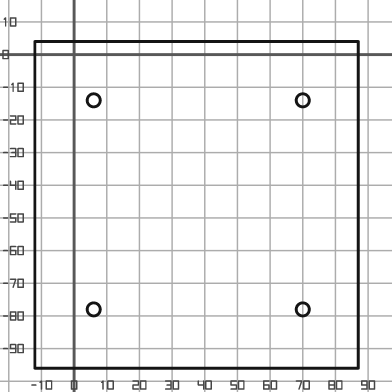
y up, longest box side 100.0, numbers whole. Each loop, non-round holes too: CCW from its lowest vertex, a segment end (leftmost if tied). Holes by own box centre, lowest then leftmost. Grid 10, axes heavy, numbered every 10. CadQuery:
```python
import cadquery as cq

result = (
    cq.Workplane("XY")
    .moveTo(-12.0, -96.0)
    .lineTo(87.0, -96.0)
    .lineTo(87.0, 4.0)
    .lineTo(-12.0, 4.0)
    .close()
    .moveTo(6.0, -78.0)
    .circle(2.0)
    .moveTo(70.0, -78.0)
    .circle(2.0)
    .moveTo(6.0, -14.0)
    .circle(2.0)
    .moveTo(70.0, -14.0)
    .circle(2.0)
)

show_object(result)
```